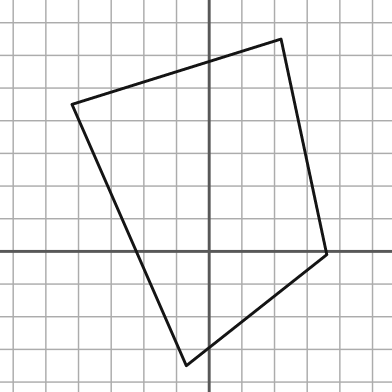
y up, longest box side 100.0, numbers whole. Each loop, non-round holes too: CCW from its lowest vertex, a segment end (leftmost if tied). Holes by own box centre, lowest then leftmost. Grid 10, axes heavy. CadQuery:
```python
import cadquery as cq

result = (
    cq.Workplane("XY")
    .moveTo(-7.0, -35.0)
    .lineTo(36.0, -1.0)
    .lineTo(22.0, 65.0)
    .lineTo(-42.0, 45.0)
    .close()
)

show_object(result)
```